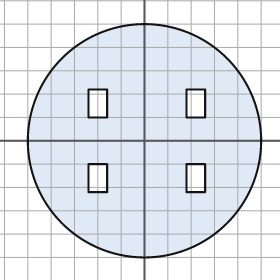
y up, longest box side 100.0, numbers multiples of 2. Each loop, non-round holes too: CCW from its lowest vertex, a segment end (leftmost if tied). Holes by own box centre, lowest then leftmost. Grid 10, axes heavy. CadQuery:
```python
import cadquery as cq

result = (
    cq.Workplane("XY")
    .moveTo(0.0, 0.0)
    .circle(50.0)
    .moveTo(-24.0, -22.0)
    .lineTo(-16.0, -22.0)
    .lineTo(-16.0, -10.0)
    .lineTo(-24.0, -10.0)
    .close()
    .moveTo(18.0, -22.0)
    .lineTo(26.0, -22.0)
    .lineTo(26.0, -10.0)
    .lineTo(18.0, -10.0)
    .close()
    .moveTo(-24.0, 10.0)
    .lineTo(-16.0, 10.0)
    .lineTo(-16.0, 22.0)
    .lineTo(-24.0, 22.0)
    .close()
    .moveTo(18.0, 10.0)
    .lineTo(26.0, 10.0)
    .lineTo(26.0, 22.0)
    .lineTo(18.0, 22.0)
    .close()
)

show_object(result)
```